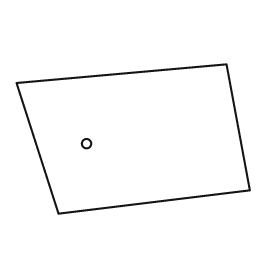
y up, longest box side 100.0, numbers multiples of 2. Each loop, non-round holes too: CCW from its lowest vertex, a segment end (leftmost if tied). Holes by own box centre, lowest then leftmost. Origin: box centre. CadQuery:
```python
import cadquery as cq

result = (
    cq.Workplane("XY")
    .moveTo(-32.0, -32.0)
    .lineTo(50.0, -22.0)
    .lineTo(40.0, 32.0)
    .lineTo(-50.0, 24.0)
    .close()
    .moveTo(-20.0, -2.0)
    .circle(2.0)
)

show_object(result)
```